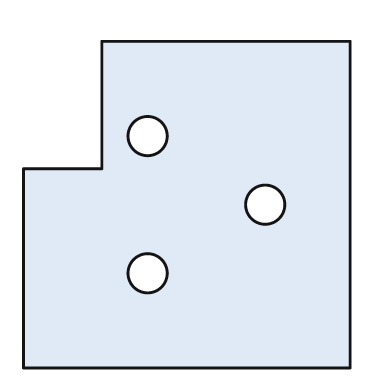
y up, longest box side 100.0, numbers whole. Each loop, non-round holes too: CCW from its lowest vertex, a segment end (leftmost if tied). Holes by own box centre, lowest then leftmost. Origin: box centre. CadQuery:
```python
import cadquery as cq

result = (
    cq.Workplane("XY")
    .moveTo(-50.0, -50.0)
    .lineTo(50.0, -50.0)
    .lineTo(50.0, 50.0)
    .lineTo(-26.0, 50.0)
    .lineTo(-26.0, 11.0)
    .lineTo(-50.0, 11.0)
    .close()
    .moveTo(-12.0, -21.0)
    .circle(6.0)
    .moveTo(24.0, 0.0)
    .circle(6.0)
    .moveTo(-12.0, 21.0)
    .circle(6.0)
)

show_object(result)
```